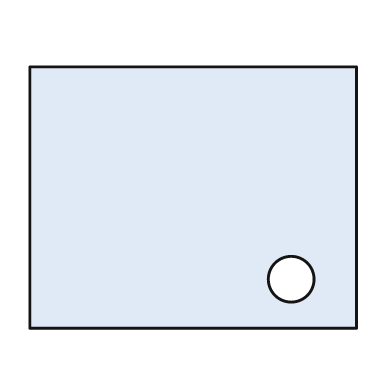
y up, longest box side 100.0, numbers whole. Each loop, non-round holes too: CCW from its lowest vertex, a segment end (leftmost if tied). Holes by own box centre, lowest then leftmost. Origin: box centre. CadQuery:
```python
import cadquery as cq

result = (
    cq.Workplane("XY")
    .moveTo(-50.0, -40.0)
    .lineTo(50.0, -40.0)
    .lineTo(50.0, 40.0)
    .lineTo(-50.0, 40.0)
    .close()
    .moveTo(30.0, -25.0)
    .circle(7.0)
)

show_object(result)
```